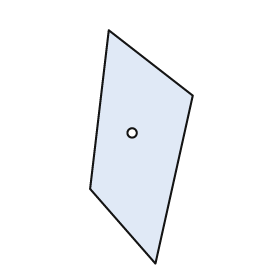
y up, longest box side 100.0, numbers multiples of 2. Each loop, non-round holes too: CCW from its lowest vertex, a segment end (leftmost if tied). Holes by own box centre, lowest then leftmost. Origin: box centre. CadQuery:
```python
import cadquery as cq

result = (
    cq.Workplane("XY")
    .moveTo(6.0, -50.0)
    .lineTo(22.0, 22.0)
    .lineTo(-14.0, 50.0)
    .lineTo(-22.0, -18.0)
    .close()
    .moveTo(-4.0, 6.0)
    .circle(2.0)
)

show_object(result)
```